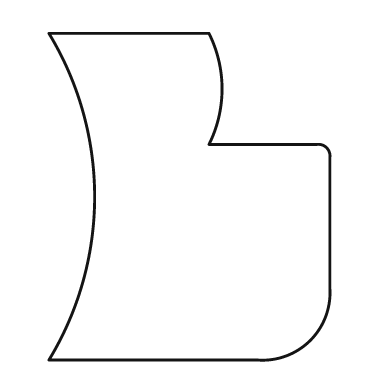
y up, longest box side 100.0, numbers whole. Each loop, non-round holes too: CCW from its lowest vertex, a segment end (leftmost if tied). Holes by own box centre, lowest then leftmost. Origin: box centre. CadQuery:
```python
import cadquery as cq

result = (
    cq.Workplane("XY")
    .moveTo(-43.0, -50.0)
    .lineTo(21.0, -50.0)
    .threePointArc((37.0, -44.0), (43.0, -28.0))
    .lineTo(43.0, 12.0)
    .threePointArc((42.0, 15.0), (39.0, 16.0))
    .lineTo(6.0, 16.0)
    .threePointArc((10.0, 33.0), (6.0, 50.0))
    .lineTo(-43.0, 50.0)
    .threePointArc((-29.0, 0.0), (-43.0, -50.0))
    .close()
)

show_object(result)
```